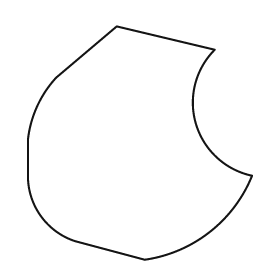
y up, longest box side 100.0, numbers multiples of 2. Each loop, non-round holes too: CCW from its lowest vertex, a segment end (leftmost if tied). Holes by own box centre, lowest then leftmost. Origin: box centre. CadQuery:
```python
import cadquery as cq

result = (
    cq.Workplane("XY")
    .moveTo(2.0, -50.0)
    .threePointArc((30.0, -38.0), (48.0, -14.0))
    .threePointArc((24.0, 8.0), (32.0, 40.0))
    .lineTo(-10.0, 50.0)
    .lineTo(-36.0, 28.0)
    .threePointArc((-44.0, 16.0), (-48.0, 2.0))
    .lineTo(-48.0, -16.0)
    .threePointArc((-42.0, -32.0), (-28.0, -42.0))
    .close()
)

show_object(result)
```